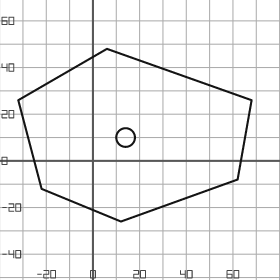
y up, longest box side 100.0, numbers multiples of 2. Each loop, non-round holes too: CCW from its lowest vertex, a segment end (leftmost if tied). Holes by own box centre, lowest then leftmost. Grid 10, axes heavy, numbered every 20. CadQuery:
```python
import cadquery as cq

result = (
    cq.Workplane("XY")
    .moveTo(12.0, -26.0)
    .lineTo(62.0, -8.0)
    .lineTo(68.0, 26.0)
    .lineTo(6.0, 48.0)
    .lineTo(-32.0, 26.0)
    .lineTo(-22.0, -12.0)
    .close()
    .moveTo(14.0, 10.0)
    .circle(4.0)
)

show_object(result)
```